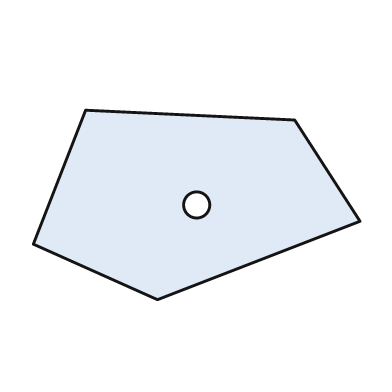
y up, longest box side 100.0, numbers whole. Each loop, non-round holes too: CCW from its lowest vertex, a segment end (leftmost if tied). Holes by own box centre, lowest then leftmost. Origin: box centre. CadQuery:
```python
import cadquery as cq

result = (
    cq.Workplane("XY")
    .moveTo(-12.0, -29.0)
    .lineTo(50.0, -5.0)
    .lineTo(30.0, 26.0)
    .lineTo(-34.0, 29.0)
    .lineTo(-50.0, -12.0)
    .close()
    .moveTo(0.0, 0.0)
    .circle(4.0)
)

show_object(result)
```